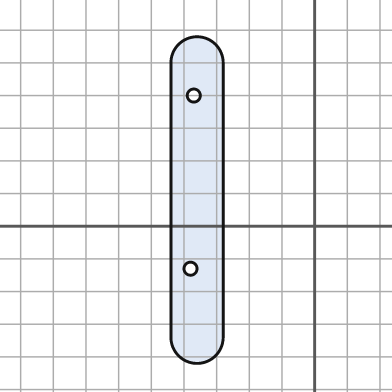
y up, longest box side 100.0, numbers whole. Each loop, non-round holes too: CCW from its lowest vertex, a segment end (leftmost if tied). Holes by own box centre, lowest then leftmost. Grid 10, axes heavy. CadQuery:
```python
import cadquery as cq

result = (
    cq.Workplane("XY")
    .moveTo(-44.0, -34.0)
    .threePointArc((-36.0, -42.0), (-28.0, -34.0))
    .lineTo(-28.0, 50.0)
    .threePointArc((-36.0, 58.0), (-44.0, 50.0))
    .close()
    .moveTo(-38.0, -13.0)
    .circle(2.0)
    .moveTo(-37.0, 40.0)
    .circle(2.0)
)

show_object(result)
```